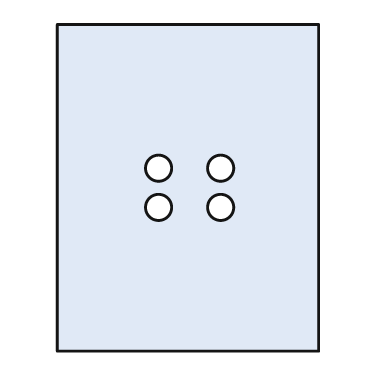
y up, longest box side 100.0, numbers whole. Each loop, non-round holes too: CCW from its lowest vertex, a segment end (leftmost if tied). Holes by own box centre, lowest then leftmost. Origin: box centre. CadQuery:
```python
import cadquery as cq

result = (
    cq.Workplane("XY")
    .moveTo(-40.0, -50.0)
    .lineTo(40.0, -50.0)
    .lineTo(40.0, 50.0)
    .lineTo(-40.0, 50.0)
    .close()
    .moveTo(-9.0, -6.0)
    .circle(4.0)
    .moveTo(10.0, -6.0)
    .circle(4.0)
    .moveTo(-9.0, 6.0)
    .circle(4.0)
    .moveTo(10.0, 6.0)
    .circle(4.0)
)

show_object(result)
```